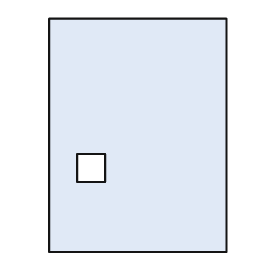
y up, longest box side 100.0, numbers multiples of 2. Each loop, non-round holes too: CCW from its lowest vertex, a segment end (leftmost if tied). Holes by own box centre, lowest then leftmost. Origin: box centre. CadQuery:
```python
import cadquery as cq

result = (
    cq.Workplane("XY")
    .moveTo(-38.0, -50.0)
    .lineTo(38.0, -50.0)
    .lineTo(38.0, 50.0)
    .lineTo(-38.0, 50.0)
    .close()
    .moveTo(-26.0, -20.0)
    .lineTo(-14.0, -20.0)
    .lineTo(-14.0, -8.0)
    .lineTo(-26.0, -8.0)
    .close()
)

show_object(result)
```